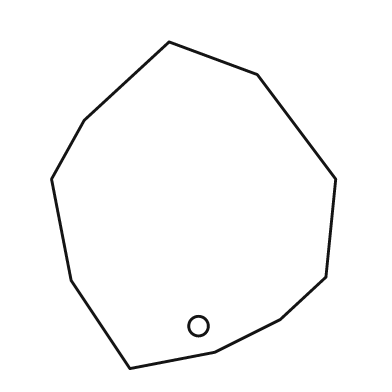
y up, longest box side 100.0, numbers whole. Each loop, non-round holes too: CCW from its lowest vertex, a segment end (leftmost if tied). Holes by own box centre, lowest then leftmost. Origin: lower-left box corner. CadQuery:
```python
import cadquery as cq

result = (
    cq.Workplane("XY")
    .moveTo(24.0, 0.0)
    .lineTo(50.0, 5.0)
    .lineTo(70.0, 15.0)
    .lineTo(84.0, 28.0)
    .lineTo(87.0, 58.0)
    .lineTo(63.0, 90.0)
    .lineTo(36.0, 100.0)
    .lineTo(10.0, 76.0)
    .lineTo(0.0, 58.0)
    .lineTo(6.0, 27.0)
    .close()
    .moveTo(45.0, 13.0)
    .circle(3.0)
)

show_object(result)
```